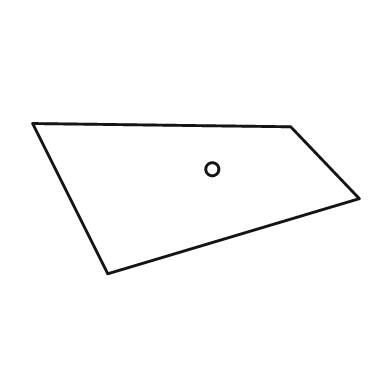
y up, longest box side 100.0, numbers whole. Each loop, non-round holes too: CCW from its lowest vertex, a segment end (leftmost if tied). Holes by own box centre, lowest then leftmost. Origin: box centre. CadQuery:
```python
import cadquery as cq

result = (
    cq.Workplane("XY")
    .moveTo(-27.0, -23.0)
    .lineTo(50.0, 0.0)
    .lineTo(29.0, 22.0)
    .lineTo(-50.0, 23.0)
    .close()
    .moveTo(5.0, 9.0)
    .circle(2.0)
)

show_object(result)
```